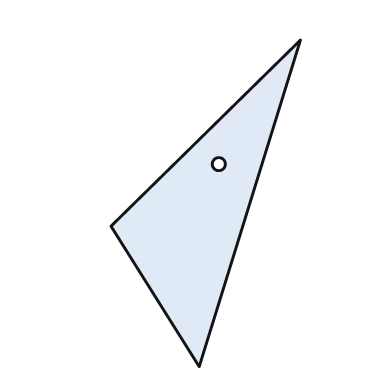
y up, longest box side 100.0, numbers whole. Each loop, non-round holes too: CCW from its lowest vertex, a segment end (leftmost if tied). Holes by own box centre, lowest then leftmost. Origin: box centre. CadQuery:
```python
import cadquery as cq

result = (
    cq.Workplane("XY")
    .moveTo(-2.0, -50.0)
    .lineTo(29.0, 50.0)
    .lineTo(-29.0, -7.0)
    .close()
    .moveTo(4.0, 12.0)
    .circle(2.0)
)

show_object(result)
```